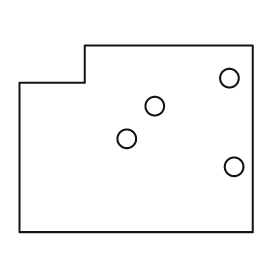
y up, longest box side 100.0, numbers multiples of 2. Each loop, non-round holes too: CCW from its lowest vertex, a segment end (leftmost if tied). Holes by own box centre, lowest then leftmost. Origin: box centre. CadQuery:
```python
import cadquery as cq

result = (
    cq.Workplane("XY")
    .moveTo(-50.0, -40.0)
    .lineTo(50.0, -40.0)
    .lineTo(50.0, 40.0)
    .lineTo(-22.0, 40.0)
    .lineTo(-22.0, 24.0)
    .lineTo(-50.0, 24.0)
    .close()
    .moveTo(42.0, -12.0)
    .circle(4.0)
    .moveTo(-4.0, 0.0)
    .circle(4.0)
    .moveTo(8.0, 14.0)
    .circle(4.0)
    .moveTo(40.0, 26.0)
    .circle(4.0)
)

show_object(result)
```